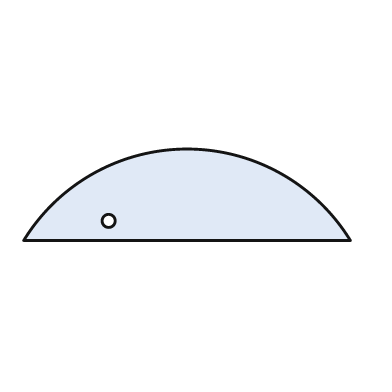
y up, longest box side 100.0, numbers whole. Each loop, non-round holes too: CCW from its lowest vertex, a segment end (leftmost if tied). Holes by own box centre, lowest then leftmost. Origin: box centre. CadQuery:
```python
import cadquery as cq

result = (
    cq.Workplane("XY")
    .moveTo(-50.0, -14.0)
    .lineTo(50.0, -14.0)
    .threePointArc((0.0, 14.0), (-50.0, -14.0))
    .close()
    .moveTo(-24.0, -8.0)
    .circle(2.0)
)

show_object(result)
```